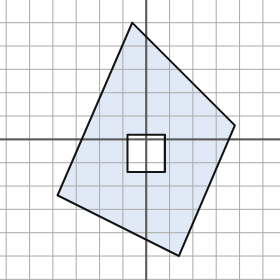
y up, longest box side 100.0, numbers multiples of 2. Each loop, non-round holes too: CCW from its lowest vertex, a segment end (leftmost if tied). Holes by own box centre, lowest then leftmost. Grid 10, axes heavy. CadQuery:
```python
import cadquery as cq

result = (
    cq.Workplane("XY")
    .moveTo(14.0, -50.0)
    .lineTo(38.0, 6.0)
    .lineTo(-6.0, 50.0)
    .lineTo(-38.0, -24.0)
    .close()
    .moveTo(-8.0, -14.0)
    .lineTo(8.0, -14.0)
    .lineTo(8.0, 2.0)
    .lineTo(-8.0, 2.0)
    .close()
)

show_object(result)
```